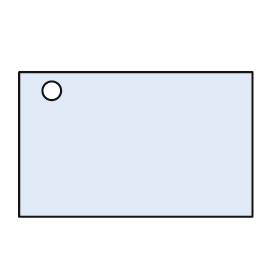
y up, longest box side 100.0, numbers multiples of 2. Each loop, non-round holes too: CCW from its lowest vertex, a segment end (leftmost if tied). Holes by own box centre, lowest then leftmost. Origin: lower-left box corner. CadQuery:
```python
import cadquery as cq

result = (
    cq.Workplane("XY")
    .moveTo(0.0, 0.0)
    .lineTo(100.0, 0.0)
    .lineTo(100.0, 62.0)
    .lineTo(0.0, 62.0)
    .close()
    .moveTo(14.0, 54.0)
    .circle(4.0)
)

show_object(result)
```